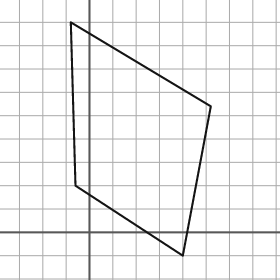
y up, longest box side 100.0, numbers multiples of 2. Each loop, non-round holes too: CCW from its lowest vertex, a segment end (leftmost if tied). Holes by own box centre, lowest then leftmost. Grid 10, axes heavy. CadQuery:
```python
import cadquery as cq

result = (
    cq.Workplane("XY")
    .moveTo(40.0, -10.0)
    .lineTo(52.0, 54.0)
    .lineTo(-8.0, 90.0)
    .lineTo(-6.0, 20.0)
    .close()
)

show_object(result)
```